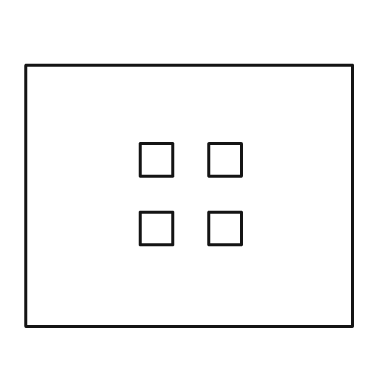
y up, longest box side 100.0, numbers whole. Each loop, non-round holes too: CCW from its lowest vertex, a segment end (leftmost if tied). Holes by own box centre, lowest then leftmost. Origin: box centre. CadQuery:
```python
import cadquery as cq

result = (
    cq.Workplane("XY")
    .moveTo(-50.0, -40.0)
    .lineTo(50.0, -40.0)
    .lineTo(50.0, 40.0)
    .lineTo(-50.0, 40.0)
    .close()
    .moveTo(-15.0, -15.0)
    .lineTo(-5.0, -15.0)
    .lineTo(-5.0, -5.0)
    .lineTo(-15.0, -5.0)
    .close()
    .moveTo(6.0, -15.0)
    .lineTo(16.0, -15.0)
    .lineTo(16.0, -5.0)
    .lineTo(6.0, -5.0)
    .close()
    .moveTo(-15.0, 6.0)
    .lineTo(-5.0, 6.0)
    .lineTo(-5.0, 16.0)
    .lineTo(-15.0, 16.0)
    .close()
    .moveTo(6.0, 6.0)
    .lineTo(16.0, 6.0)
    .lineTo(16.0, 16.0)
    .lineTo(6.0, 16.0)
    .close()
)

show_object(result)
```